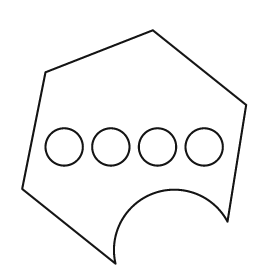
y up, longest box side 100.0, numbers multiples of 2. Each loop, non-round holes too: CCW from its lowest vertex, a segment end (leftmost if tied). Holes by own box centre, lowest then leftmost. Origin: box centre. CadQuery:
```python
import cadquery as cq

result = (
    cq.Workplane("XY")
    .moveTo(-8.0, -50.0)
    .threePointArc((8.0, -20.0), (40.0, -32.0))
    .lineTo(48.0, 18.0)
    .lineTo(8.0, 50.0)
    .lineTo(-38.0, 32.0)
    .lineTo(-48.0, -18.0)
    .close()
    .moveTo(-30.0, 0.0)
    .circle(8.0)
    .moveTo(-10.0, 0.0)
    .circle(8.0)
    .moveTo(10.0, 0.0)
    .circle(8.0)
    .moveTo(30.0, 0.0)
    .circle(8.0)
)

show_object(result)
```